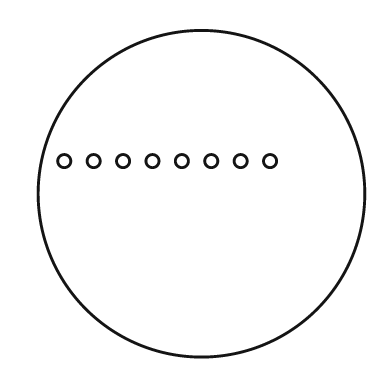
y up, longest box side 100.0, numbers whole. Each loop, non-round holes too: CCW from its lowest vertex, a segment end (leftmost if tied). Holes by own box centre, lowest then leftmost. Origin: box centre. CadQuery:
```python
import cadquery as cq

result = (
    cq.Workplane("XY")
    .moveTo(0.0, 0.0)
    .circle(50.0)
    .moveTo(-42.0, 10.0)
    .circle(2.0)
    .moveTo(-33.0, 10.0)
    .circle(2.0)
    .moveTo(-24.0, 10.0)
    .circle(2.0)
    .moveTo(-15.0, 10.0)
    .circle(2.0)
    .moveTo(-6.0, 10.0)
    .circle(2.0)
    .moveTo(3.0, 10.0)
    .circle(2.0)
    .moveTo(12.0, 10.0)
    .circle(2.0)
    .moveTo(21.0, 10.0)
    .circle(2.0)
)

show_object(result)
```